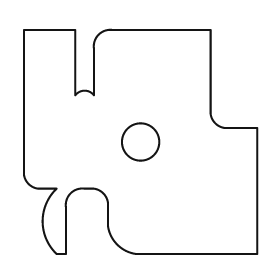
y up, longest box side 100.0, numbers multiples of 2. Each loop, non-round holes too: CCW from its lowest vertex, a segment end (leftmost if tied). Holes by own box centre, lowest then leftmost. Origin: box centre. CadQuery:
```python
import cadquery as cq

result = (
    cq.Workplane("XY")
    .moveTo(-36.0, -48.0)
    .lineTo(-32.0, -48.0)
    .lineTo(-32.0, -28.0)
    .threePointArc((-30.0, -22.0), (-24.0, -20.0))
    .lineTo(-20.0, -20.0)
    .threePointArc((-16.0, -22.0), (-14.0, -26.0))
    .lineTo(-14.0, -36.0)
    .threePointArc((-10.0, -44.0), (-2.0, -48.0))
    .lineTo(50.0, -48.0)
    .lineTo(50.0, 6.0)
    .lineTo(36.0, 6.0)
    .threePointArc((32.0, 8.0), (30.0, 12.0))
    .lineTo(30.0, 48.0)
    .lineTo(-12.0, 48.0)
    .threePointArc((-18.0, 46.0), (-20.0, 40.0))
    .lineTo(-20.0, 20.0)
    .threePointArc((-24.0, 22.0), (-28.0, 20.0))
    .lineTo(-28.0, 48.0)
    .lineTo(-50.0, 48.0)
    .lineTo(-50.0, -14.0)
    .threePointArc((-48.0, -18.0), (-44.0, -20.0))
    .lineTo(-36.0, -20.0)
    .threePointArc((-42.0, -34.0), (-36.0, -48.0))
    .close()
    .moveTo(0.0, 0.0)
    .circle(8.0)
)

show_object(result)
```